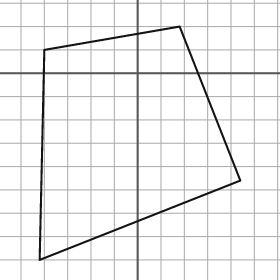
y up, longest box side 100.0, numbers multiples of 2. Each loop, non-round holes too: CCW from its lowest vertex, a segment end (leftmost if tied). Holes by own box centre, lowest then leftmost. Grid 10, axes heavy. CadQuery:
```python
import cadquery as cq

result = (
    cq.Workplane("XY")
    .moveTo(-42.0, -80.0)
    .lineTo(44.0, -46.0)
    .lineTo(18.0, 20.0)
    .lineTo(-40.0, 10.0)
    .close()
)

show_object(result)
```